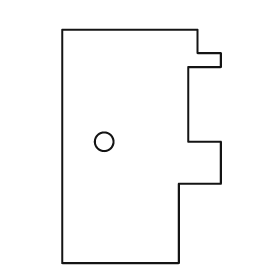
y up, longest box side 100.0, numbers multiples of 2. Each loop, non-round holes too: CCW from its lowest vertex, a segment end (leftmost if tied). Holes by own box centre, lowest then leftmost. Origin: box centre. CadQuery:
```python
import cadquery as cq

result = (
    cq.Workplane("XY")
    .moveTo(-34.0, -50.0)
    .lineTo(16.0, -50.0)
    .lineTo(16.0, -16.0)
    .lineTo(34.0, -16.0)
    .lineTo(34.0, 2.0)
    .lineTo(20.0, 2.0)
    .lineTo(20.0, 34.0)
    .lineTo(34.0, 34.0)
    .lineTo(34.0, 40.0)
    .lineTo(24.0, 40.0)
    .lineTo(24.0, 50.0)
    .lineTo(-34.0, 50.0)
    .close()
    .moveTo(-16.0, 2.0)
    .circle(4.0)
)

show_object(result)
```